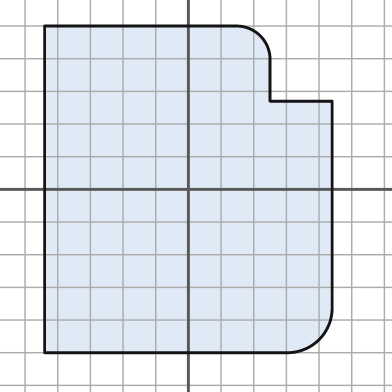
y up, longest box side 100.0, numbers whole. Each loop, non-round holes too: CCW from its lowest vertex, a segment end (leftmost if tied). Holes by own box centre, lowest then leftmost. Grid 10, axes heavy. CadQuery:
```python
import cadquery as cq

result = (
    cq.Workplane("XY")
    .moveTo(-44.0, -50.0)
    .lineTo(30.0, -50.0)
    .threePointArc((40.0, -46.0), (44.0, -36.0))
    .lineTo(44.0, 27.0)
    .lineTo(25.0, 27.0)
    .lineTo(25.0, 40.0)
    .threePointArc((22.0, 47.0), (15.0, 50.0))
    .lineTo(-44.0, 50.0)
    .close()
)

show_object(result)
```